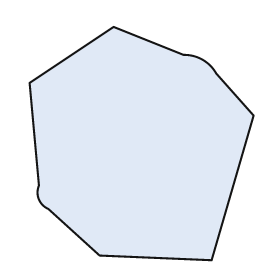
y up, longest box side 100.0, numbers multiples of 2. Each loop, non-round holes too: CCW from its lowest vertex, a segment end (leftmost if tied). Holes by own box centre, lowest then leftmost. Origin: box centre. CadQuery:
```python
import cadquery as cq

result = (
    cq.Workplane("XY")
    .moveTo(30.0, -50.0)
    .lineTo(48.0, 12.0)
    .lineTo(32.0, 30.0)
    .threePointArc((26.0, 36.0), (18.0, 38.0))
    .lineTo(-12.0, 50.0)
    .lineTo(-48.0, 26.0)
    .lineTo(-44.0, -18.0)
    .threePointArc((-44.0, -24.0), (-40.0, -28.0))
    .lineTo(-18.0, -48.0)
    .close()
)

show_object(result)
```